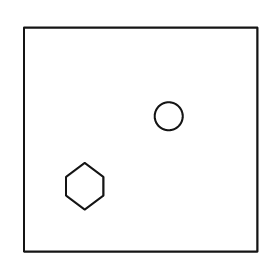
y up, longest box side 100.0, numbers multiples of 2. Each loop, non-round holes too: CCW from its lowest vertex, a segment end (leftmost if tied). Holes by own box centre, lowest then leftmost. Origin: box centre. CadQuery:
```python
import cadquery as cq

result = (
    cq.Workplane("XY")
    .moveTo(-50.0, -48.0)
    .lineTo(50.0, -48.0)
    .lineTo(50.0, 48.0)
    .lineTo(-50.0, 48.0)
    .close()
    .moveTo(-24.0, -30.0)
    .lineTo(-16.0, -24.0)
    .lineTo(-16.0, -16.0)
    .lineTo(-24.0, -10.0)
    .lineTo(-32.0, -16.0)
    .lineTo(-32.0, -24.0)
    .close()
    .moveTo(12.0, 10.0)
    .circle(6.0)
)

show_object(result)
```